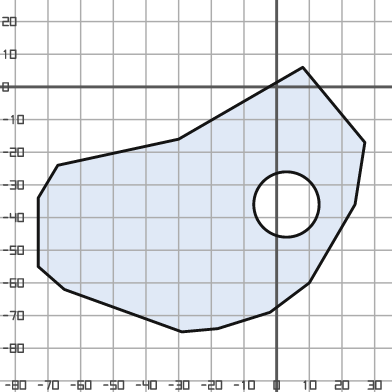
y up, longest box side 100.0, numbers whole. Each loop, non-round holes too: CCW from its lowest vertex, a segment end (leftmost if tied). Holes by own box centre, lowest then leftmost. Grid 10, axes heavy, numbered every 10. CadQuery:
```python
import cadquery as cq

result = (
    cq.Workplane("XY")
    .moveTo(-29.0, -75.0)
    .lineTo(-18.0, -74.0)
    .lineTo(-2.0, -69.0)
    .lineTo(10.0, -60.0)
    .lineTo(24.0, -36.0)
    .lineTo(27.0, -17.0)
    .lineTo(8.0, 6.0)
    .lineTo(-30.0, -16.0)
    .lineTo(-67.0, -24.0)
    .lineTo(-73.0, -34.0)
    .lineTo(-73.0, -55.0)
    .lineTo(-65.0, -62.0)
    .close()
    .moveTo(3.0, -36.0)
    .circle(10.0)
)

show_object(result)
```